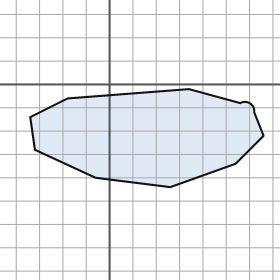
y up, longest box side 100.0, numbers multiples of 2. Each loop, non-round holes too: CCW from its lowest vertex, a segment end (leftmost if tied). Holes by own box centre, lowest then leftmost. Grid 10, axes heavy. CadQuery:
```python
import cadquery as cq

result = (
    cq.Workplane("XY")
    .moveTo(26.0, -44.0)
    .lineTo(54.0, -34.0)
    .lineTo(66.0, -22.0)
    .lineTo(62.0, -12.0)
    .threePointArc((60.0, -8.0), (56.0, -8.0))
    .lineTo(34.0, -2.0)
    .lineTo(-18.0, -6.0)
    .lineTo(-34.0, -14.0)
    .lineTo(-32.0, -28.0)
    .lineTo(-6.0, -40.0)
    .close()
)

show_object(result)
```